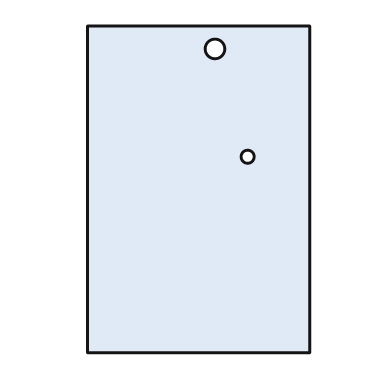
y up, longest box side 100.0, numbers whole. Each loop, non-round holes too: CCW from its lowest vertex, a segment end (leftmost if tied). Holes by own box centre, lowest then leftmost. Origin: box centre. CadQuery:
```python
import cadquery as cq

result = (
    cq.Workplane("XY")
    .moveTo(-34.0, -50.0)
    .lineTo(34.0, -50.0)
    .lineTo(34.0, 50.0)
    .lineTo(-34.0, 50.0)
    .close()
    .moveTo(15.0, 10.0)
    .circle(2.0)
    .moveTo(5.0, 43.0)
    .circle(3.0)
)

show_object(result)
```